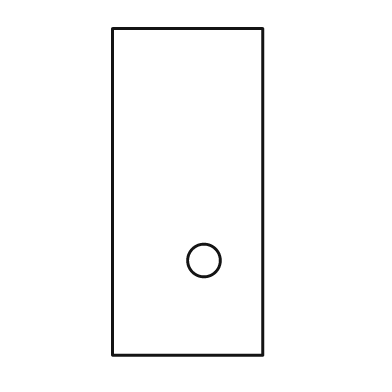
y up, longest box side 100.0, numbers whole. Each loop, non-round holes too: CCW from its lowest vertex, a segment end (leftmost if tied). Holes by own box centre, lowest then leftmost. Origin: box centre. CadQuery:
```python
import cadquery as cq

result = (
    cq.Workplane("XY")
    .moveTo(-23.0, -50.0)
    .lineTo(23.0, -50.0)
    .lineTo(23.0, 50.0)
    .lineTo(-23.0, 50.0)
    .close()
    .moveTo(5.0, -21.0)
    .circle(5.0)
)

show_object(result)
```